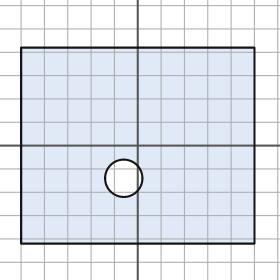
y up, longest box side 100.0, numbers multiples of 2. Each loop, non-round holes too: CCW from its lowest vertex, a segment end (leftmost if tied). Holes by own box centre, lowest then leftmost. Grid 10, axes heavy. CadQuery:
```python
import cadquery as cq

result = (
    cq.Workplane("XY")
    .moveTo(-50.0, -42.0)
    .lineTo(50.0, -42.0)
    .lineTo(50.0, 42.0)
    .lineTo(-50.0, 42.0)
    .close()
    .moveTo(-6.0, -14.0)
    .circle(8.0)
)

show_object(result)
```